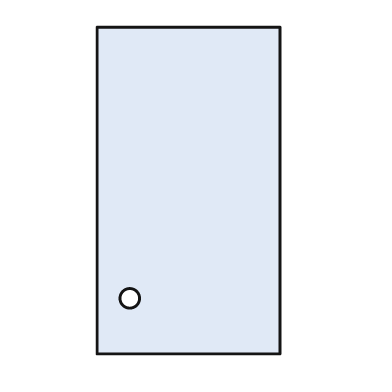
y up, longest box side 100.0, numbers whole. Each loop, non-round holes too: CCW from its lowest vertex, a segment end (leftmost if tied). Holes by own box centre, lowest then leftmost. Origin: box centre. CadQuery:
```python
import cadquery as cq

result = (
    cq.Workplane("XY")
    .moveTo(-28.0, -50.0)
    .lineTo(28.0, -50.0)
    .lineTo(28.0, 50.0)
    .lineTo(-28.0, 50.0)
    .close()
    .moveTo(-18.0, -33.0)
    .circle(3.0)
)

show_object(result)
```